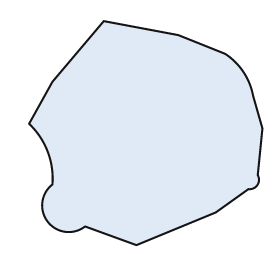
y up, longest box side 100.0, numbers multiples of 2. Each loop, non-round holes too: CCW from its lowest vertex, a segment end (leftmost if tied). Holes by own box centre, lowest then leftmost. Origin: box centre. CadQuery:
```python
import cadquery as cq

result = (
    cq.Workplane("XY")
    .moveTo(-4.0, -48.0)
    .lineTo(30.0, -34.0)
    .lineTo(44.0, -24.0)
    .threePointArc((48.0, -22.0), (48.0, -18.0))
    .lineTo(50.0, 2.0)
    .lineTo(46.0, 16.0)
    .threePointArc((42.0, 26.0), (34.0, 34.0))
    .lineTo(14.0, 42.0)
    .lineTo(-18.0, 48.0)
    .lineTo(-40.0, 22.0)
    .lineTo(-50.0, 4.0)
    .threePointArc((-42.0, -8.0), (-40.0, -22.0))
    .threePointArc((-42.0, -38.0), (-26.0, -40.0))
    .close()
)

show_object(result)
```